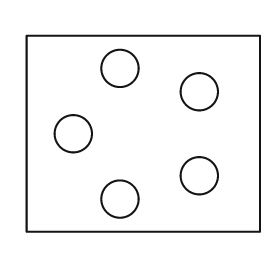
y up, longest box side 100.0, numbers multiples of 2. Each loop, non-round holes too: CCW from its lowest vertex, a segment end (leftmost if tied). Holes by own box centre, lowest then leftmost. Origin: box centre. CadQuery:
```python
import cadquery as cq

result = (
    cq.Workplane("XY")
    .moveTo(-50.0, -42.0)
    .lineTo(50.0, -42.0)
    .lineTo(50.0, 42.0)
    .lineTo(-50.0, 42.0)
    .close()
    .moveTo(-10.0, -28.0)
    .circle(8.0)
    .moveTo(24.0, -18.0)
    .circle(8.0)
    .moveTo(-30.0, 0.0)
    .circle(8.0)
    .moveTo(24.0, 18.0)
    .circle(8.0)
    .moveTo(-10.0, 28.0)
    .circle(8.0)
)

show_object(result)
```